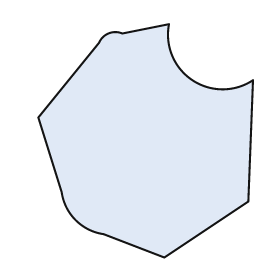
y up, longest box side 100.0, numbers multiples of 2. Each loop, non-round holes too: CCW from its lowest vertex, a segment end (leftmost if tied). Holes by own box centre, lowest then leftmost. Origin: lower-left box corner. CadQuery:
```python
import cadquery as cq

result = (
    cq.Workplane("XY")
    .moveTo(54.0, 0.0)
    .lineTo(90.0, 24.0)
    .lineTo(92.0, 76.0)
    .threePointArc((66.0, 76.0), (56.0, 100.0))
    .lineTo(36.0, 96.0)
    .threePointArc((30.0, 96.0), (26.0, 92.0))
    .lineTo(0.0, 60.0)
    .lineTo(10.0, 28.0)
    .threePointArc((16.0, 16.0), (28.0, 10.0))
    .close()
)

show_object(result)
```